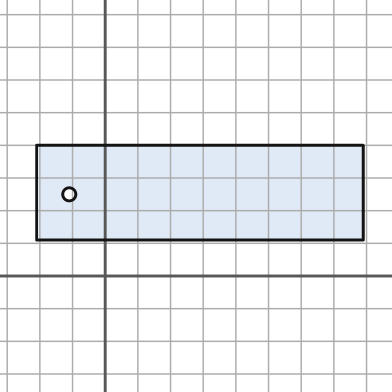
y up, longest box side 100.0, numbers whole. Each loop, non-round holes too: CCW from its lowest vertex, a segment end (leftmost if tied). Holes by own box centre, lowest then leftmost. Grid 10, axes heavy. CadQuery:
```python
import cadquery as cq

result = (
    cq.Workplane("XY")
    .moveTo(-21.0, 11.0)
    .lineTo(79.0, 11.0)
    .lineTo(79.0, 40.0)
    .lineTo(-21.0, 40.0)
    .close()
    .moveTo(-11.0, 25.0)
    .circle(2.0)
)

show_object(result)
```